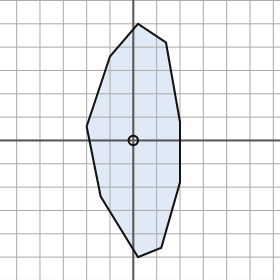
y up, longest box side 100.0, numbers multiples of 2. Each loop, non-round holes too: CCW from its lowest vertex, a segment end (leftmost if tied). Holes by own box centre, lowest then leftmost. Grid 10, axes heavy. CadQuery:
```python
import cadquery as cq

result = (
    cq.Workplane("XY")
    .moveTo(2.0, -50.0)
    .lineTo(12.0, -46.0)
    .lineTo(20.0, -18.0)
    .lineTo(20.0, 8.0)
    .lineTo(14.0, 42.0)
    .lineTo(2.0, 50.0)
    .lineTo(-10.0, 36.0)
    .lineTo(-20.0, 6.0)
    .lineTo(-14.0, -24.0)
    .close()
    .moveTo(0.0, 0.0)
    .circle(2.0)
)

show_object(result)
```